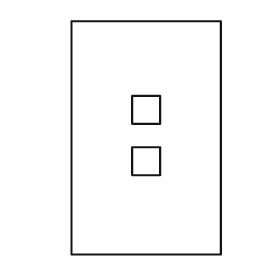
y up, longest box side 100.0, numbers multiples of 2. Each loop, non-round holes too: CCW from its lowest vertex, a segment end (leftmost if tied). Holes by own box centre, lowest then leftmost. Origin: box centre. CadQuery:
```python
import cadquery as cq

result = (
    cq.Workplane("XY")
    .moveTo(-32.0, -50.0)
    .lineTo(32.0, -50.0)
    .lineTo(32.0, 50.0)
    .lineTo(-32.0, 50.0)
    .close()
    .moveTo(-6.0, -16.0)
    .lineTo(6.0, -16.0)
    .lineTo(6.0, -4.0)
    .lineTo(-6.0, -4.0)
    .close()
    .moveTo(-6.0, 6.0)
    .lineTo(6.0, 6.0)
    .lineTo(6.0, 18.0)
    .lineTo(-6.0, 18.0)
    .close()
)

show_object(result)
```